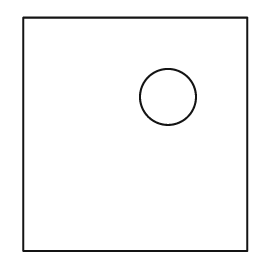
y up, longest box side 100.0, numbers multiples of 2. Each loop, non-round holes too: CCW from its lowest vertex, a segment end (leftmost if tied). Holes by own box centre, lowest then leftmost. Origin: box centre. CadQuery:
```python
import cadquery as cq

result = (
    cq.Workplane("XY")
    .moveTo(-48.0, -50.0)
    .lineTo(48.0, -50.0)
    .lineTo(48.0, 50.0)
    .lineTo(-48.0, 50.0)
    .close()
    .moveTo(14.0, 16.0)
    .circle(12.0)
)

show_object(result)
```